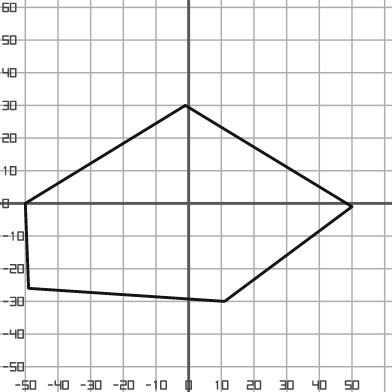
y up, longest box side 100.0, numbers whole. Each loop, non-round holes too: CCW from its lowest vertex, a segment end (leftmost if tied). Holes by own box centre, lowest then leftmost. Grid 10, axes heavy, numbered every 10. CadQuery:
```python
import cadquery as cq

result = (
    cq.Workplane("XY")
    .moveTo(11.0, -30.0)
    .lineTo(50.0, -1.0)
    .lineTo(-1.0, 30.0)
    .lineTo(-50.0, 0.0)
    .lineTo(-49.0, -26.0)
    .close()
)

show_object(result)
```